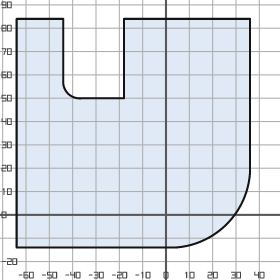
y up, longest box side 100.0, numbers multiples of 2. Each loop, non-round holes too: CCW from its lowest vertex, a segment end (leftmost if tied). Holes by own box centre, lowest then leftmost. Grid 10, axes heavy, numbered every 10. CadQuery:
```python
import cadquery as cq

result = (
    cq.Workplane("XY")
    .moveTo(-64.0, -14.0)
    .lineTo(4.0, -14.0)
    .threePointArc((26.0, -4.0), (36.0, 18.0))
    .lineTo(36.0, 84.0)
    .lineTo(-18.0, 84.0)
    .lineTo(-18.0, 50.0)
    .lineTo(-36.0, 50.0)
    .threePointArc((-42.0, 52.0), (-44.0, 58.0))
    .lineTo(-44.0, 84.0)
    .lineTo(-64.0, 84.0)
    .close()
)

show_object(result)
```